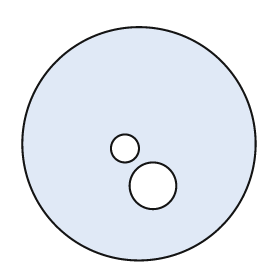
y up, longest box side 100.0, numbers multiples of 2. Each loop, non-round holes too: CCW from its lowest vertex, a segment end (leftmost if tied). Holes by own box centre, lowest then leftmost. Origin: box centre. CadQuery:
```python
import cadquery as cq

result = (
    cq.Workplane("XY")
    .moveTo(0.0, 0.0)
    .circle(50.0)
    .moveTo(6.0, -18.0)
    .circle(10.0)
    .moveTo(-6.0, -2.0)
    .circle(6.0)
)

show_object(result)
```